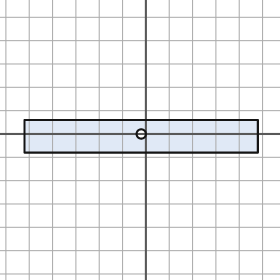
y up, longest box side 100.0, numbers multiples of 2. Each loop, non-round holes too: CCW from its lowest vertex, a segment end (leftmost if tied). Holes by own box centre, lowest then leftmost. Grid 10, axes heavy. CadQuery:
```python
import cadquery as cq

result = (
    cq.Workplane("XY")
    .moveTo(-52.0, -8.0)
    .lineTo(48.0, -8.0)
    .lineTo(48.0, 6.0)
    .lineTo(-52.0, 6.0)
    .close()
    .moveTo(-2.0, 0.0)
    .circle(2.0)
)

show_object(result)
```